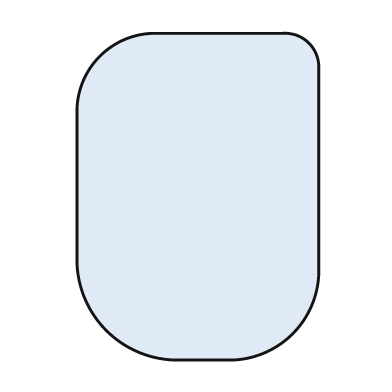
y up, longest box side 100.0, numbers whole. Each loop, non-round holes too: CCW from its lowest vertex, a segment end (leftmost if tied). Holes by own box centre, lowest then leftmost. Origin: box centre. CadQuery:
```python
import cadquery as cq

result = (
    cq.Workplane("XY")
    .moveTo(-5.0, -50.0)
    .lineTo(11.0, -50.0)
    .threePointArc((29.0, -42.0), (37.0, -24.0))
    .lineTo(37.0, 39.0)
    .threePointArc((34.0, 47.0), (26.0, 50.0))
    .lineTo(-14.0, 50.0)
    .threePointArc((-30.0, 43.0), (-37.0, 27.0))
    .lineTo(-37.0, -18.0)
    .threePointArc((-28.0, -41.0), (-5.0, -50.0))
    .close()
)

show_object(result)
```